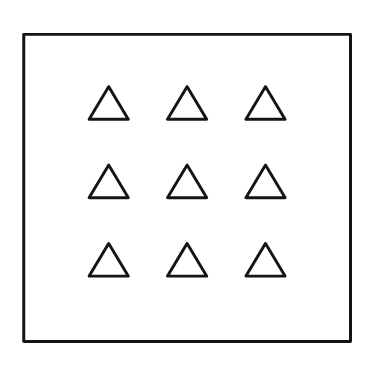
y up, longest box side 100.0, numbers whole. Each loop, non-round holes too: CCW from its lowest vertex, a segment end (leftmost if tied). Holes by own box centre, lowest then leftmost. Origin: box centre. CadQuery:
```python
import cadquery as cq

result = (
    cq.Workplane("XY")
    .moveTo(-50.0, -47.0)
    .lineTo(50.0, -47.0)
    .lineTo(50.0, 47.0)
    .lineTo(-50.0, 47.0)
    .close()
    .moveTo(-30.0, -27.0)
    .lineTo(-18.0, -27.0)
    .lineTo(-24.0, -17.0)
    .close()
    .moveTo(-6.0, -27.0)
    .lineTo(6.0, -27.0)
    .lineTo(0.0, -17.0)
    .close()
    .moveTo(18.0, -27.0)
    .lineTo(30.0, -27.0)
    .lineTo(24.0, -17.0)
    .close()
    .moveTo(-30.0, -3.0)
    .lineTo(-18.0, -3.0)
    .lineTo(-24.0, 7.0)
    .close()
    .moveTo(-6.0, -3.0)
    .lineTo(6.0, -3.0)
    .lineTo(0.0, 7.0)
    .close()
    .moveTo(18.0, -3.0)
    .lineTo(30.0, -3.0)
    .lineTo(24.0, 7.0)
    .close()
    .moveTo(-30.0, 21.0)
    .lineTo(-18.0, 21.0)
    .lineTo(-24.0, 31.0)
    .close()
    .moveTo(-6.0, 21.0)
    .lineTo(6.0, 21.0)
    .lineTo(0.0, 31.0)
    .close()
    .moveTo(18.0, 21.0)
    .lineTo(30.0, 21.0)
    .lineTo(24.0, 31.0)
    .close()
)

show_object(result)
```